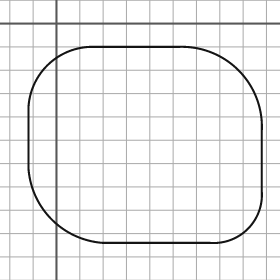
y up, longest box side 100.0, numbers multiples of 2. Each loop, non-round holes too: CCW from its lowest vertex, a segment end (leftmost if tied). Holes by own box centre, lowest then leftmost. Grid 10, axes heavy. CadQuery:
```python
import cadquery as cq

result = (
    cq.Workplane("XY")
    .moveTo(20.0, -94.0)
    .lineTo(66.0, -94.0)
    .threePointArc((82.0, -88.0), (88.0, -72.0))
    .lineTo(88.0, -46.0)
    .threePointArc((78.0, -20.0), (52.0, -10.0))
    .lineTo(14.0, -10.0)
    .threePointArc((-4.0, -18.0), (-12.0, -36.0))
    .lineTo(-12.0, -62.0)
    .threePointArc((-2.0, -84.0), (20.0, -94.0))
    .close()
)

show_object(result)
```